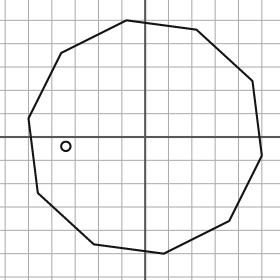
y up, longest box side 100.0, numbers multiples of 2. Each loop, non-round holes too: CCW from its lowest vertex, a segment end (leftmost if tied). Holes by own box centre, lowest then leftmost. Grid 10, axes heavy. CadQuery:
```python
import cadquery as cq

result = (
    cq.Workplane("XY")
    .moveTo(8.0, -50.0)
    .lineTo(36.0, -36.0)
    .lineTo(50.0, -8.0)
    .lineTo(46.0, 24.0)
    .lineTo(22.0, 46.0)
    .lineTo(-8.0, 50.0)
    .lineTo(-36.0, 36.0)
    .lineTo(-50.0, 8.0)
    .lineTo(-46.0, -24.0)
    .lineTo(-22.0, -46.0)
    .close()
    .moveTo(-34.0, -4.0)
    .circle(2.0)
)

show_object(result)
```